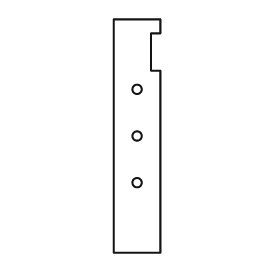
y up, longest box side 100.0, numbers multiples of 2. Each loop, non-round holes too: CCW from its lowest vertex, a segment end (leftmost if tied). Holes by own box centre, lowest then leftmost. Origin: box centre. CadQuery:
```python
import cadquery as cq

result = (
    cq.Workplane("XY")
    .moveTo(-10.0, -50.0)
    .lineTo(10.0, -50.0)
    .lineTo(10.0, 28.0)
    .lineTo(6.0, 28.0)
    .lineTo(6.0, 44.0)
    .lineTo(10.0, 44.0)
    .lineTo(10.0, 50.0)
    .lineTo(-10.0, 50.0)
    .close()
    .moveTo(0.0, -20.0)
    .circle(2.0)
    .moveTo(0.0, 0.0)
    .circle(2.0)
    .moveTo(0.0, 20.0)
    .circle(2.0)
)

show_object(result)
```